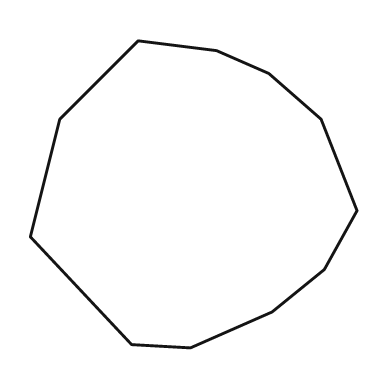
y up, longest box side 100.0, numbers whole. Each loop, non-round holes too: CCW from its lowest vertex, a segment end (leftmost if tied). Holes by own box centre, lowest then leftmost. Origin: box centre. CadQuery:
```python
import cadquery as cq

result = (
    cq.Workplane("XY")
    .moveTo(-1.0, -47.0)
    .lineTo(24.0, -36.0)
    .lineTo(40.0, -23.0)
    .lineTo(50.0, -5.0)
    .lineTo(39.0, 23.0)
    .lineTo(23.0, 37.0)
    .lineTo(7.0, 44.0)
    .lineTo(-17.0, 47.0)
    .lineTo(-41.0, 23.0)
    .lineTo(-50.0, -13.0)
    .lineTo(-19.0, -46.0)
    .close()
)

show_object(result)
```